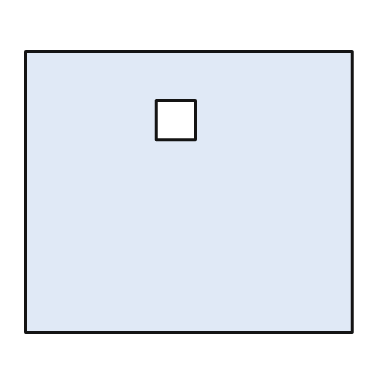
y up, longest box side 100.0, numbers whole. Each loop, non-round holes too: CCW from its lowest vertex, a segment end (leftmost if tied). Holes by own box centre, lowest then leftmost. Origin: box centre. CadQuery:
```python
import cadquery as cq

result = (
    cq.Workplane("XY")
    .moveTo(-50.0, -43.0)
    .lineTo(50.0, -43.0)
    .lineTo(50.0, 43.0)
    .lineTo(-50.0, 43.0)
    .close()
    .moveTo(-10.0, 16.0)
    .lineTo(2.0, 16.0)
    .lineTo(2.0, 28.0)
    .lineTo(-10.0, 28.0)
    .close()
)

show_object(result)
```